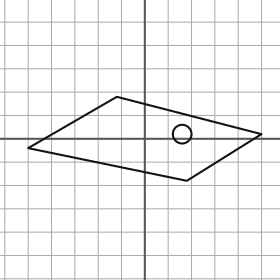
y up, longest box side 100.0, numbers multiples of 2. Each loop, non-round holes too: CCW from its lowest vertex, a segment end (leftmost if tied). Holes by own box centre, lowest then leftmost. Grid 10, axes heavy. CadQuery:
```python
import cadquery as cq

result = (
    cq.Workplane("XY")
    .moveTo(18.0, -18.0)
    .lineTo(50.0, 2.0)
    .lineTo(-12.0, 18.0)
    .lineTo(-50.0, -4.0)
    .close()
    .moveTo(16.0, 2.0)
    .circle(4.0)
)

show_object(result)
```